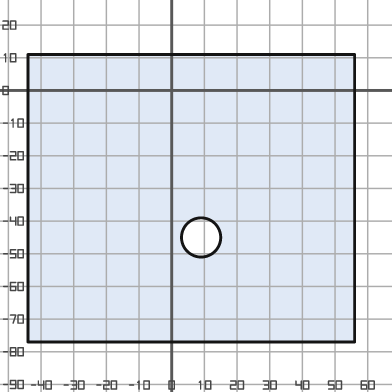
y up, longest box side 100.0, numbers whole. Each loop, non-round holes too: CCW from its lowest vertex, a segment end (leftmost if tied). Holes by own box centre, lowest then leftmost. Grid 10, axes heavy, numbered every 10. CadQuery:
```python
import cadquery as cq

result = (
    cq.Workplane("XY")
    .moveTo(-44.0, -77.0)
    .lineTo(56.0, -77.0)
    .lineTo(56.0, 11.0)
    .lineTo(-44.0, 11.0)
    .close()
    .moveTo(9.0, -45.0)
    .circle(6.0)
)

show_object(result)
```